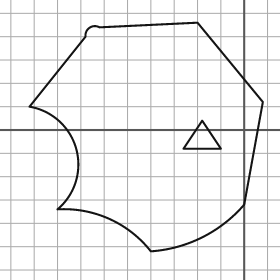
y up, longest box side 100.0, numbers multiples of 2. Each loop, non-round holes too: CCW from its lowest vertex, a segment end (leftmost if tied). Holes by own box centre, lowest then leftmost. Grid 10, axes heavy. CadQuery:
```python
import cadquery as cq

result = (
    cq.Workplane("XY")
    .moveTo(-40.0, -52.0)
    .threePointArc((-18.0, -46.0), (0.0, -32.0))
    .lineTo(8.0, 12.0)
    .lineTo(-20.0, 46.0)
    .lineTo(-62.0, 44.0)
    .threePointArc((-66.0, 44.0), (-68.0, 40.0))
    .lineTo(-92.0, 10.0)
    .threePointArc((-72.0, -8.0), (-80.0, -34.0))
    .threePointArc((-58.0, -38.0), (-40.0, -52.0))
    .close()
    .moveTo(-26.0, -8.0)
    .lineTo(-10.0, -8.0)
    .lineTo(-18.0, 4.0)
    .close()
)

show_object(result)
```